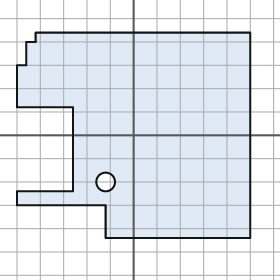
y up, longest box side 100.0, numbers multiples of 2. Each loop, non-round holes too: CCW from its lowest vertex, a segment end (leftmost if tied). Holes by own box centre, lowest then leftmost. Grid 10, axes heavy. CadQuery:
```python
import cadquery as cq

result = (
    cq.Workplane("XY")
    .moveTo(-12.0, -44.0)
    .lineTo(50.0, -44.0)
    .lineTo(50.0, 44.0)
    .lineTo(-42.0, 44.0)
    .lineTo(-42.0, 40.0)
    .lineTo(-46.0, 40.0)
    .lineTo(-46.0, 30.0)
    .lineTo(-50.0, 30.0)
    .lineTo(-50.0, 12.0)
    .lineTo(-26.0, 12.0)
    .lineTo(-26.0, -24.0)
    .lineTo(-50.0, -24.0)
    .lineTo(-50.0, -30.0)
    .lineTo(-12.0, -30.0)
    .close()
    .moveTo(-12.0, -20.0)
    .circle(4.0)
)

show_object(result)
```